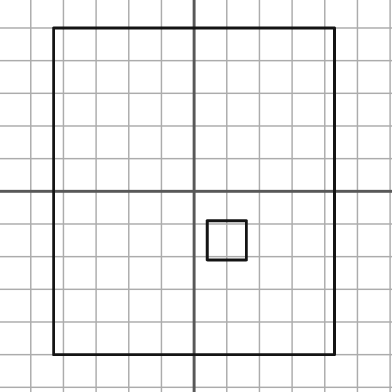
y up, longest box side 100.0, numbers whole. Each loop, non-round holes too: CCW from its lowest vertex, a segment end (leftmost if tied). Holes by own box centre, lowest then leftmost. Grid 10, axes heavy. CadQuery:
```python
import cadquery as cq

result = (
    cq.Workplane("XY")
    .moveTo(-43.0, -50.0)
    .lineTo(43.0, -50.0)
    .lineTo(43.0, 50.0)
    .lineTo(-43.0, 50.0)
    .close()
    .moveTo(4.0, -21.0)
    .lineTo(16.0, -21.0)
    .lineTo(16.0, -9.0)
    .lineTo(4.0, -9.0)
    .close()
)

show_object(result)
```